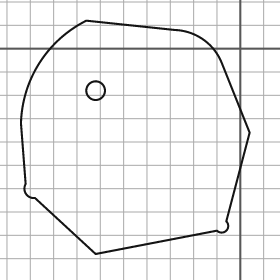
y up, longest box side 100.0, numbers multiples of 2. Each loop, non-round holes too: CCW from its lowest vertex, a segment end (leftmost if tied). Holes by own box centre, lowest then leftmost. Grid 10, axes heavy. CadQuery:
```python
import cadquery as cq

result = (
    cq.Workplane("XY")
    .moveTo(-62.0, -88.0)
    .lineTo(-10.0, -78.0)
    .threePointArc((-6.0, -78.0), (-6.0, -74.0))
    .lineTo(4.0, -36.0)
    .lineTo(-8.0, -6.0)
    .threePointArc((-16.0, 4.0), (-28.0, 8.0))
    .lineTo(-66.0, 12.0)
    .threePointArc((-86.0, -6.0), (-94.0, -32.0))
    .lineTo(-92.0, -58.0)
    .threePointArc((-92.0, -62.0), (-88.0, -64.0))
    .close()
    .moveTo(-62.0, -18.0)
    .circle(4.0)
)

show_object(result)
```